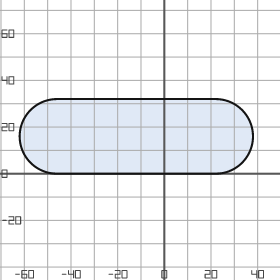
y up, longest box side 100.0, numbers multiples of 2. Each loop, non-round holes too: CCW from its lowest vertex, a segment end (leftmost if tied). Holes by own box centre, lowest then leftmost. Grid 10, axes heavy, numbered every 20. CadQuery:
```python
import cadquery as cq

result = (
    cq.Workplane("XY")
    .moveTo(-46.0, 0.0)
    .lineTo(22.0, 0.0)
    .threePointArc((38.0, 16.0), (22.0, 32.0))
    .lineTo(-46.0, 32.0)
    .threePointArc((-62.0, 16.0), (-46.0, 0.0))
    .close()
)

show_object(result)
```